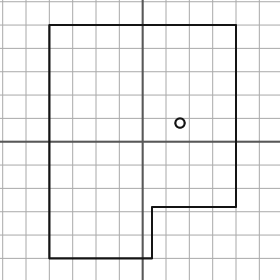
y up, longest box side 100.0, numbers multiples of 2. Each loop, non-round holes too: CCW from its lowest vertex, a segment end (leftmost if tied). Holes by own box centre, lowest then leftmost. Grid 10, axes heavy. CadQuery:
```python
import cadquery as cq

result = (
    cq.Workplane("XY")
    .moveTo(-40.0, -50.0)
    .lineTo(4.0, -50.0)
    .lineTo(4.0, -28.0)
    .lineTo(40.0, -28.0)
    .lineTo(40.0, 50.0)
    .lineTo(-40.0, 50.0)
    .close()
    .moveTo(16.0, 8.0)
    .circle(2.0)
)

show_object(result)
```